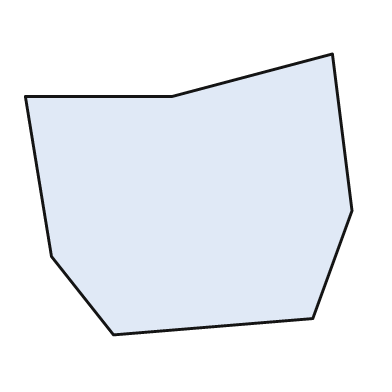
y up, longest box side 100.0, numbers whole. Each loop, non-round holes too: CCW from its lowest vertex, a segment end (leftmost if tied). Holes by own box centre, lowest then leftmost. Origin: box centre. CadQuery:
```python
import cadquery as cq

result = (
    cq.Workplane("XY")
    .moveTo(-23.0, -43.0)
    .lineTo(38.0, -38.0)
    .lineTo(50.0, -5.0)
    .lineTo(44.0, 43.0)
    .lineTo(-5.0, 30.0)
    .lineTo(-50.0, 30.0)
    .lineTo(-42.0, -19.0)
    .close()
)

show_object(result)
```